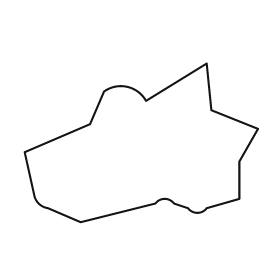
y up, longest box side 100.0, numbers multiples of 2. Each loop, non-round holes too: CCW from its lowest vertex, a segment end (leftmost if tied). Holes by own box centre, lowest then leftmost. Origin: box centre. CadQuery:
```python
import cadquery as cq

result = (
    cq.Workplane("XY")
    .moveTo(-26.0, -34.0)
    .lineTo(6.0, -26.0)
    .threePointArc((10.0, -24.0), (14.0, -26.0))
    .lineTo(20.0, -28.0)
    .threePointArc((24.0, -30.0), (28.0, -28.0))
    .lineTo(42.0, -24.0)
    .lineTo(42.0, -8.0)
    .lineTo(50.0, 6.0)
    .lineTo(30.0, 14.0)
    .lineTo(28.0, 34.0)
    .lineTo(2.0, 18.0)
    .threePointArc((-6.0, 24.0), (-16.0, 22.0))
    .lineTo(-22.0, 8.0)
    .lineTo(-50.0, -4.0)
    .lineTo(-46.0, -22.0)
    .threePointArc((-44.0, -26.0), (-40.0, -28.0))
    .close()
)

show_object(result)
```